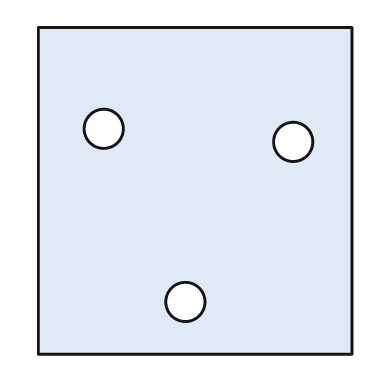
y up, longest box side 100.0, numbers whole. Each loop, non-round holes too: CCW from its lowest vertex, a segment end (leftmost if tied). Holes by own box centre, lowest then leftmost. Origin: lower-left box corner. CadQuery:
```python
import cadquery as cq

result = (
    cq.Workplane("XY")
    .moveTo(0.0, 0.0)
    .lineTo(96.0, 0.0)
    .lineTo(96.0, 100.0)
    .lineTo(0.0, 100.0)
    .close()
    .moveTo(45.0, 16.0)
    .circle(6.0)
    .moveTo(78.0, 65.0)
    .circle(6.0)
    .moveTo(20.0, 69.0)
    .circle(6.0)
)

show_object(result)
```